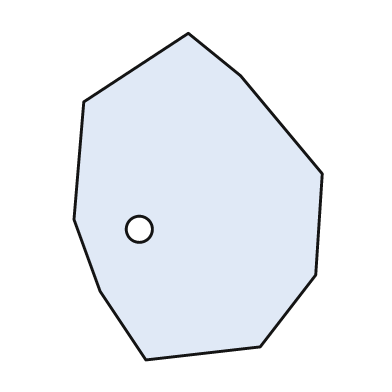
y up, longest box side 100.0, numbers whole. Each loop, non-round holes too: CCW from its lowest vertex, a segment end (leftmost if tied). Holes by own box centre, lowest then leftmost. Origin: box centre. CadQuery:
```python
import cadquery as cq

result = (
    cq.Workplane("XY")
    .moveTo(-16.0, -50.0)
    .lineTo(19.0, -46.0)
    .lineTo(36.0, -24.0)
    .lineTo(38.0, 7.0)
    .lineTo(13.0, 37.0)
    .lineTo(-3.0, 50.0)
    .lineTo(-35.0, 29.0)
    .lineTo(-38.0, -7.0)
    .lineTo(-30.0, -29.0)
    .close()
    .moveTo(-18.0, -10.0)
    .circle(4.0)
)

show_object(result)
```